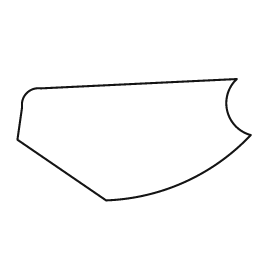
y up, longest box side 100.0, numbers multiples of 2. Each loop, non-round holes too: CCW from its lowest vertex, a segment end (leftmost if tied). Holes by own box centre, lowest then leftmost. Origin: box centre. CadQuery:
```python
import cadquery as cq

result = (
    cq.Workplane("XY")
    .moveTo(-12.0, -26.0)
    .threePointArc((22.0, -18.0), (50.0, 2.0))
    .threePointArc((40.0, 12.0), (44.0, 26.0))
    .lineTo(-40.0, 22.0)
    .threePointArc((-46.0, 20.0), (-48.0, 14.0))
    .lineTo(-50.0, 0.0)
    .close()
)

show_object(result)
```